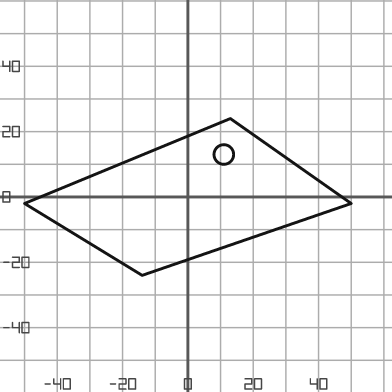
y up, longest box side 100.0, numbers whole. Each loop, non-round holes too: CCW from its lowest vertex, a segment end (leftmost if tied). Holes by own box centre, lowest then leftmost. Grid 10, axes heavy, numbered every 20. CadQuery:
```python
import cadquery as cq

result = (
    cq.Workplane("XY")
    .moveTo(-14.0, -24.0)
    .lineTo(50.0, -2.0)
    .lineTo(13.0, 24.0)
    .lineTo(-50.0, -2.0)
    .close()
    .moveTo(11.0, 13.0)
    .circle(3.0)
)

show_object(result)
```